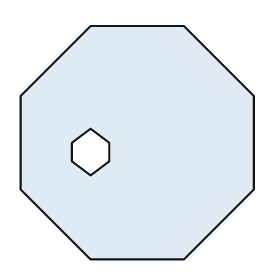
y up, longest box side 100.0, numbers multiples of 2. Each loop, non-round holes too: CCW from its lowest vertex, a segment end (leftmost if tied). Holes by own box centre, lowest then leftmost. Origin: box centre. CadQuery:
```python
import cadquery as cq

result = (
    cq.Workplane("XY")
    .moveTo(-20.0, -50.0)
    .lineTo(20.0, -50.0)
    .lineTo(50.0, -20.0)
    .lineTo(50.0, 20.0)
    .lineTo(20.0, 50.0)
    .lineTo(-20.0, 50.0)
    .lineTo(-50.0, 20.0)
    .lineTo(-50.0, -20.0)
    .close()
    .moveTo(-20.0, -14.0)
    .lineTo(-12.0, -8.0)
    .lineTo(-12.0, 0.0)
    .lineTo(-20.0, 6.0)
    .lineTo(-28.0, 0.0)
    .lineTo(-28.0, -8.0)
    .close()
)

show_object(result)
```